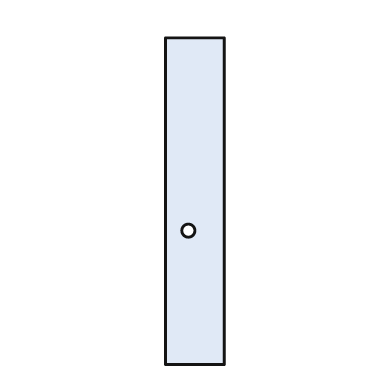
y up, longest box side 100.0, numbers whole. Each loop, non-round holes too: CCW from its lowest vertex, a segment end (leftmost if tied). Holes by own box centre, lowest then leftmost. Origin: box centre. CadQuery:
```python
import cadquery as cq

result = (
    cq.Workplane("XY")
    .moveTo(-9.0, -50.0)
    .lineTo(9.0, -50.0)
    .lineTo(9.0, 50.0)
    .lineTo(-9.0, 50.0)
    .close()
    .moveTo(-2.0, -9.0)
    .circle(2.0)
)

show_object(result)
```